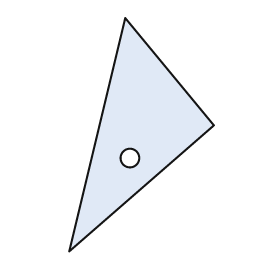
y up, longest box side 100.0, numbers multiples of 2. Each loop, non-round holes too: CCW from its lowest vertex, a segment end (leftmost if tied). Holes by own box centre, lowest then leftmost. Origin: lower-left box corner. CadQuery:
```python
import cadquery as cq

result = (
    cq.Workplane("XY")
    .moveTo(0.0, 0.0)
    .lineTo(62.0, 54.0)
    .lineTo(24.0, 100.0)
    .close()
    .moveTo(26.0, 40.0)
    .circle(4.0)
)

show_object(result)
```